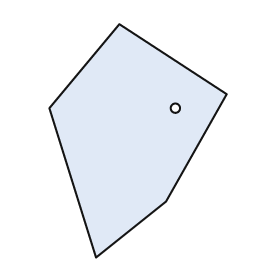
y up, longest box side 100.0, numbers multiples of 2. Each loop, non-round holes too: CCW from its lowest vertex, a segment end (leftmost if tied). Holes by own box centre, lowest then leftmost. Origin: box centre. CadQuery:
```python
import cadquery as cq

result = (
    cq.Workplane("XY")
    .moveTo(-18.0, -50.0)
    .lineTo(12.0, -26.0)
    .lineTo(38.0, 20.0)
    .lineTo(-8.0, 50.0)
    .lineTo(-38.0, 14.0)
    .close()
    .moveTo(16.0, 14.0)
    .circle(2.0)
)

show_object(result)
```